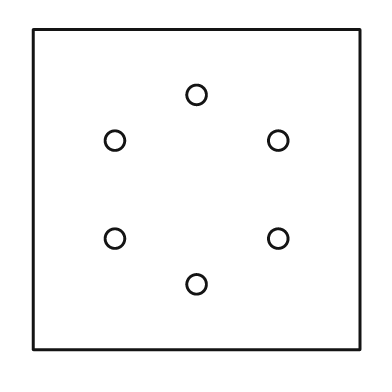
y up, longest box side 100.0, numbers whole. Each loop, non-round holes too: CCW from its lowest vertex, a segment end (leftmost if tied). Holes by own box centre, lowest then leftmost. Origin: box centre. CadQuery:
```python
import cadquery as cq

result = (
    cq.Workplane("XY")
    .moveTo(-50.0, -49.0)
    .lineTo(50.0, -49.0)
    .lineTo(50.0, 49.0)
    .lineTo(-50.0, 49.0)
    .close()
    .moveTo(0.0, -29.0)
    .circle(3.0)
    .moveTo(-25.0, -15.0)
    .circle(3.0)
    .moveTo(25.0, -15.0)
    .circle(3.0)
    .moveTo(-25.0, 15.0)
    .circle(3.0)
    .moveTo(25.0, 15.0)
    .circle(3.0)
    .moveTo(0.0, 29.0)
    .circle(3.0)
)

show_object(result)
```